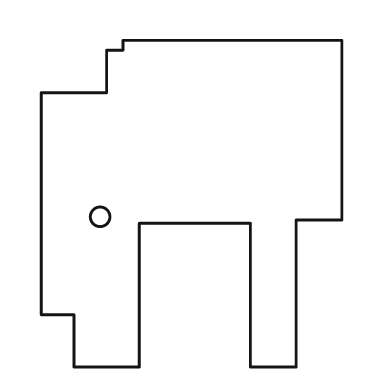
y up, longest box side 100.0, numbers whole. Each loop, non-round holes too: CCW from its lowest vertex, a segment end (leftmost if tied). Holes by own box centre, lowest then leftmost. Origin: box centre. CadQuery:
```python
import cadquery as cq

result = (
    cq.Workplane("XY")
    .moveTo(-36.0, -50.0)
    .lineTo(-16.0, -50.0)
    .lineTo(-16.0, -6.0)
    .lineTo(18.0, -6.0)
    .lineTo(18.0, -50.0)
    .lineTo(32.0, -50.0)
    .lineTo(32.0, -5.0)
    .lineTo(46.0, -5.0)
    .lineTo(46.0, 50.0)
    .lineTo(-21.0, 50.0)
    .lineTo(-21.0, 47.0)
    .lineTo(-26.0, 47.0)
    .lineTo(-26.0, 34.0)
    .lineTo(-46.0, 34.0)
    .lineTo(-46.0, -34.0)
    .lineTo(-36.0, -34.0)
    .close()
    .moveTo(-28.0, -4.0)
    .circle(3.0)
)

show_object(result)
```